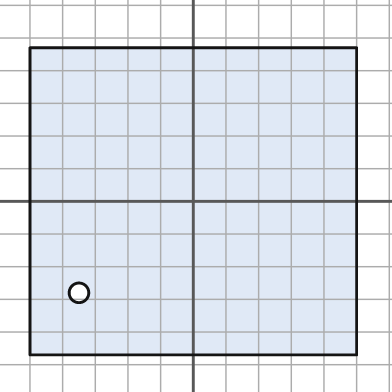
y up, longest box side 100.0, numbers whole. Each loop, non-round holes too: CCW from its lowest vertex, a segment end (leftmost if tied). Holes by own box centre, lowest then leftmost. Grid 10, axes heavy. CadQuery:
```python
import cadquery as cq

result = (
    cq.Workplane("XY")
    .moveTo(-50.0, -47.0)
    .lineTo(50.0, -47.0)
    .lineTo(50.0, 47.0)
    .lineTo(-50.0, 47.0)
    .close()
    .moveTo(-35.0, -28.0)
    .circle(3.0)
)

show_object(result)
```